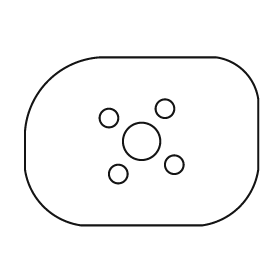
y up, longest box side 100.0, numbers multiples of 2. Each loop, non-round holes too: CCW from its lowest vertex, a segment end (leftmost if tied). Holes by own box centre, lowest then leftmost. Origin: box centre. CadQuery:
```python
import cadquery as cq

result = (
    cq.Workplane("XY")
    .moveTo(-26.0, -36.0)
    .lineTo(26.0, -36.0)
    .threePointArc((42.0, -28.0), (50.0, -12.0))
    .lineTo(50.0, 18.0)
    .threePointArc((44.0, 30.0), (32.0, 36.0))
    .lineTo(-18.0, 36.0)
    .threePointArc((-40.0, 26.0), (-50.0, 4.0))
    .lineTo(-50.0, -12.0)
    .threePointArc((-42.0, -28.0), (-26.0, -36.0))
    .close()
    .moveTo(-10.0, -14.0)
    .circle(4.0)
    .moveTo(14.0, -10.0)
    .circle(4.0)
    .moveTo(0.0, 0.0)
    .circle(8.0)
    .moveTo(-14.0, 10.0)
    .circle(4.0)
    .moveTo(10.0, 14.0)
    .circle(4.0)
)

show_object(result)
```